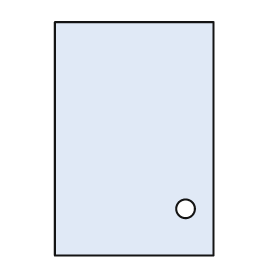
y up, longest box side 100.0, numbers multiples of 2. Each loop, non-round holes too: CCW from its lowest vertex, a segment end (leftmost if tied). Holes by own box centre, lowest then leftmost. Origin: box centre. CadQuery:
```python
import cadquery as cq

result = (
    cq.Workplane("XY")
    .moveTo(-34.0, -50.0)
    .lineTo(34.0, -50.0)
    .lineTo(34.0, 50.0)
    .lineTo(-34.0, 50.0)
    .close()
    .moveTo(22.0, -30.0)
    .circle(4.0)
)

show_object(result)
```